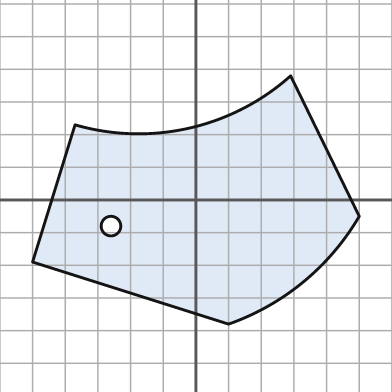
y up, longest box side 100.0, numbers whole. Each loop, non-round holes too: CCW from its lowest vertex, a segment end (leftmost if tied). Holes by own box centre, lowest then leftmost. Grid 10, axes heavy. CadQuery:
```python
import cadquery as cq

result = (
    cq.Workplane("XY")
    .moveTo(10.0, -38.0)
    .threePointArc((33.0, -25.0), (50.0, -5.0))
    .lineTo(29.0, 38.0)
    .threePointArc((-2.0, 22.0), (-37.0, 23.0))
    .lineTo(-50.0, -19.0)
    .close()
    .moveTo(-26.0, -8.0)
    .circle(3.0)
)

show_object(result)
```